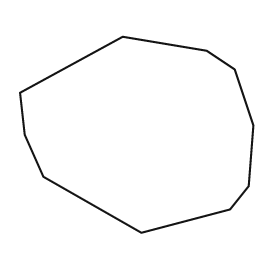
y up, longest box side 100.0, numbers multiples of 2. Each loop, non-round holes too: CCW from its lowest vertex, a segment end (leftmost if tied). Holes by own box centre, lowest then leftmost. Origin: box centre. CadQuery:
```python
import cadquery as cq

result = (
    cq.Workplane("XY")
    .moveTo(2.0, -42.0)
    .lineTo(40.0, -32.0)
    .lineTo(48.0, -22.0)
    .lineTo(50.0, 4.0)
    .lineTo(42.0, 28.0)
    .lineTo(30.0, 36.0)
    .lineTo(-6.0, 42.0)
    .lineTo(-50.0, 18.0)
    .lineTo(-48.0, 0.0)
    .lineTo(-40.0, -18.0)
    .close()
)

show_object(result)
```